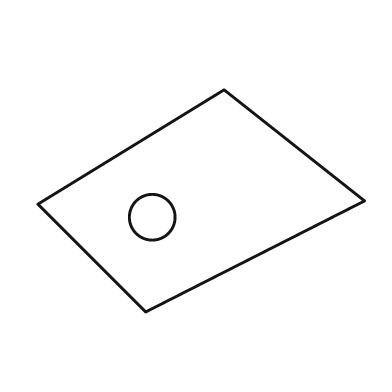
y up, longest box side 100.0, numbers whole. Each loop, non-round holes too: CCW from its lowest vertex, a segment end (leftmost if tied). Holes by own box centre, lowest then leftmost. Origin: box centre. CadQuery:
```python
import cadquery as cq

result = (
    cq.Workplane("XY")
    .moveTo(-17.0, -34.0)
    .lineTo(50.0, 0.0)
    .lineTo(7.0, 34.0)
    .lineTo(-50.0, -1.0)
    .close()
    .moveTo(-15.0, -5.0)
    .circle(7.0)
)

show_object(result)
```